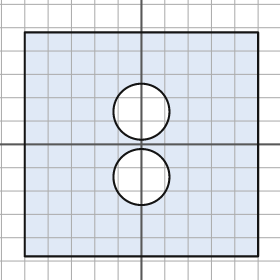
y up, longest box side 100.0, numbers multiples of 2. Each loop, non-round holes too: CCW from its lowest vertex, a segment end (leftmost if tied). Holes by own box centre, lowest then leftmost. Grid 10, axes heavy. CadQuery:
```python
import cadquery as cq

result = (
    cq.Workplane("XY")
    .moveTo(-50.0, -48.0)
    .lineTo(50.0, -48.0)
    .lineTo(50.0, 48.0)
    .lineTo(-50.0, 48.0)
    .close()
    .moveTo(0.0, -14.0)
    .circle(12.0)
    .moveTo(0.0, 14.0)
    .circle(12.0)
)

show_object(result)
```